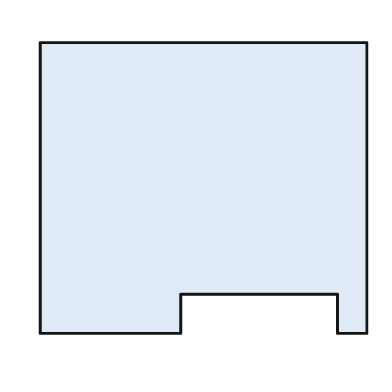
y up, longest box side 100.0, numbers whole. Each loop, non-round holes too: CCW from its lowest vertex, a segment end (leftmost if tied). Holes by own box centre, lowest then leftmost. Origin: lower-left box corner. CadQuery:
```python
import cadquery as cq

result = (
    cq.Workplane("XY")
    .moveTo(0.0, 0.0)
    .lineTo(43.0, 0.0)
    .lineTo(43.0, 12.0)
    .lineTo(91.0, 12.0)
    .lineTo(91.0, 0.0)
    .lineTo(100.0, 0.0)
    .lineTo(100.0, 89.0)
    .lineTo(0.0, 89.0)
    .close()
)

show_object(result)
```